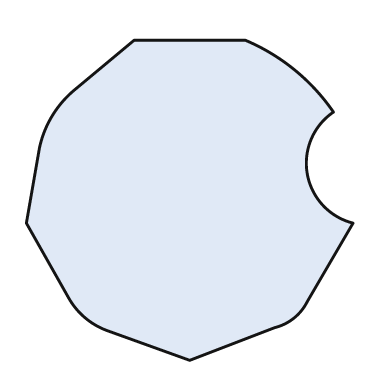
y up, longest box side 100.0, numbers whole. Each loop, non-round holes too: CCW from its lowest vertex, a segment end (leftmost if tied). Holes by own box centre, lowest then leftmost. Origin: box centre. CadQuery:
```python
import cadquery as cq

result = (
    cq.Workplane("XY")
    .moveTo(0.0, -49.0)
    .lineTo(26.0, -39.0)
    .threePointArc((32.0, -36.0), (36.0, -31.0))
    .lineTo(50.0, -7.0)
    .threePointArc((36.0, 8.0), (44.0, 27.0))
    .threePointArc((32.0, 40.0), (17.0, 49.0))
    .lineTo(-17.0, 49.0)
    .lineTo(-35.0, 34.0)
    .threePointArc((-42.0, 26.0), (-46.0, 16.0))
    .lineTo(-50.0, -7.0)
    .lineTo(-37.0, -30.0)
    .threePointArc((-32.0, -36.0), (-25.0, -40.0))
    .close()
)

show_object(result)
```